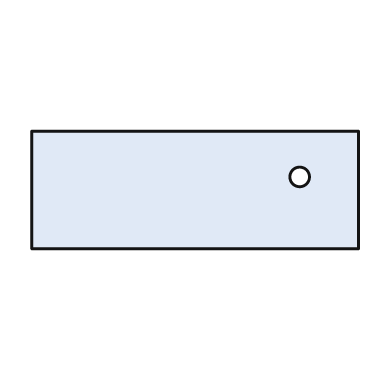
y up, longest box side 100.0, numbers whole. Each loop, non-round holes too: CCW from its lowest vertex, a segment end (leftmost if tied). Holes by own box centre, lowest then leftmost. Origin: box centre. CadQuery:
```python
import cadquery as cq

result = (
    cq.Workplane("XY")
    .moveTo(-50.0, -18.0)
    .lineTo(50.0, -18.0)
    .lineTo(50.0, 18.0)
    .lineTo(-50.0, 18.0)
    .close()
    .moveTo(32.0, 4.0)
    .circle(3.0)
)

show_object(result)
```